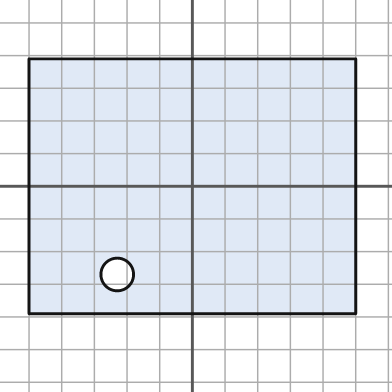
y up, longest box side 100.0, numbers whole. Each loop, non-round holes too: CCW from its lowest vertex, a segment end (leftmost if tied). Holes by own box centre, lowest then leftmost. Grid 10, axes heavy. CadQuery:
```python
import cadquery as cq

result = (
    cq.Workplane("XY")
    .moveTo(-50.0, -39.0)
    .lineTo(50.0, -39.0)
    .lineTo(50.0, 39.0)
    .lineTo(-50.0, 39.0)
    .close()
    .moveTo(-23.0, -27.0)
    .circle(5.0)
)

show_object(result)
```